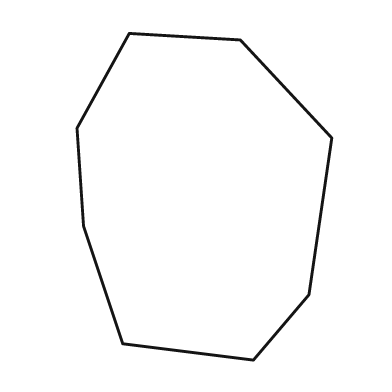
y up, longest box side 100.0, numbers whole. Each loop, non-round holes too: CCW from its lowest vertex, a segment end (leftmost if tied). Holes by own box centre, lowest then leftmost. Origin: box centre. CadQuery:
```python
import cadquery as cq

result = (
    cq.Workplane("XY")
    .moveTo(15.0, -50.0)
    .lineTo(32.0, -30.0)
    .lineTo(39.0, 18.0)
    .lineTo(11.0, 48.0)
    .lineTo(-23.0, 50.0)
    .lineTo(-39.0, 21.0)
    .lineTo(-37.0, -9.0)
    .lineTo(-25.0, -45.0)
    .close()
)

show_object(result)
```